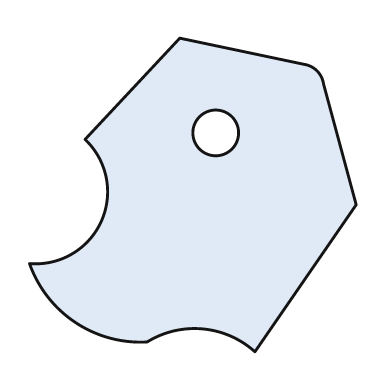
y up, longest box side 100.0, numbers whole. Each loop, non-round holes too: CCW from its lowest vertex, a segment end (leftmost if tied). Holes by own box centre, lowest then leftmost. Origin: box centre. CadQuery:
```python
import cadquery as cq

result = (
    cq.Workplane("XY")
    .moveTo(19.0, -48.0)
    .lineTo(50.0, -3.0)
    .lineTo(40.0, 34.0)
    .threePointArc((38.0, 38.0), (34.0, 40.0))
    .lineTo(-4.0, 48.0)
    .lineTo(-33.0, 17.0)
    .threePointArc((-28.0, -8.0), (-50.0, -21.0))
    .threePointArc((-36.0, -39.0), (-14.0, -45.0))
    .threePointArc((3.0, -41.0), (19.0, -48.0))
    .close()
    .moveTo(7.0, 19.0)
    .circle(7.0)
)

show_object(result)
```